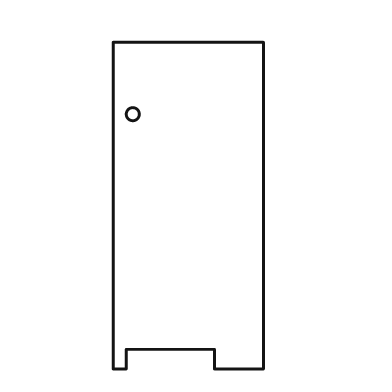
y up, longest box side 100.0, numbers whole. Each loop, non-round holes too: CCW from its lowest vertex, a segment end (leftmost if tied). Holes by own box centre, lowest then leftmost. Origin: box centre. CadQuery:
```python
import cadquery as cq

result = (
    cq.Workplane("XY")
    .moveTo(-23.0, -50.0)
    .lineTo(-19.0, -50.0)
    .lineTo(-19.0, -44.0)
    .lineTo(8.0, -44.0)
    .lineTo(8.0, -50.0)
    .lineTo(23.0, -50.0)
    .lineTo(23.0, 50.0)
    .lineTo(-23.0, 50.0)
    .close()
    .moveTo(-17.0, 28.0)
    .circle(2.0)
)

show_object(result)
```